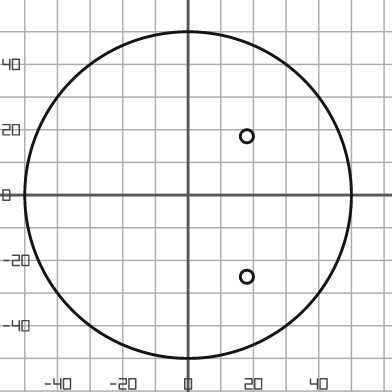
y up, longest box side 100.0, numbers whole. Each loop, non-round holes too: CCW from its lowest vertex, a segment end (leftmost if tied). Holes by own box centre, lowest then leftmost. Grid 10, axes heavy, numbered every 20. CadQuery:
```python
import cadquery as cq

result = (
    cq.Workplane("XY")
    .moveTo(0.0, 0.0)
    .circle(50.0)
    .moveTo(18.0, -25.0)
    .circle(2.0)
    .moveTo(18.0, 18.0)
    .circle(2.0)
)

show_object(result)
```